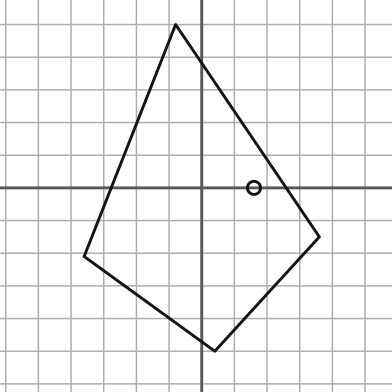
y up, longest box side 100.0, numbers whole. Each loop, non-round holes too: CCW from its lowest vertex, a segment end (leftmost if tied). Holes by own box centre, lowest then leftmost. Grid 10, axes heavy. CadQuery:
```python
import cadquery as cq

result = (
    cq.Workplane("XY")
    .moveTo(4.0, -50.0)
    .lineTo(36.0, -15.0)
    .lineTo(-8.0, 50.0)
    .lineTo(-36.0, -21.0)
    .close()
    .moveTo(16.0, 0.0)
    .circle(2.0)
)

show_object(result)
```